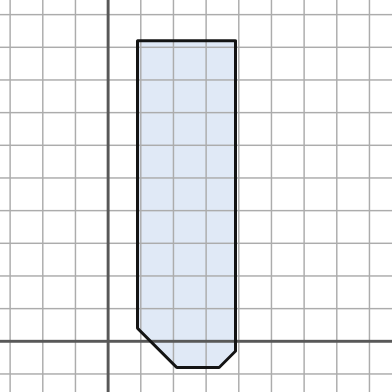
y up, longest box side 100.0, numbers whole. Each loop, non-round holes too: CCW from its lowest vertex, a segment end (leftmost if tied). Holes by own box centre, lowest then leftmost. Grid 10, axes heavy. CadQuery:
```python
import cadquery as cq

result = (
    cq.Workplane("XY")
    .moveTo(21.0, -8.0)
    .lineTo(34.0, -8.0)
    .lineTo(39.0, -3.0)
    .lineTo(39.0, 92.0)
    .lineTo(9.0, 92.0)
    .lineTo(9.0, 4.0)
    .close()
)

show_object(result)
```